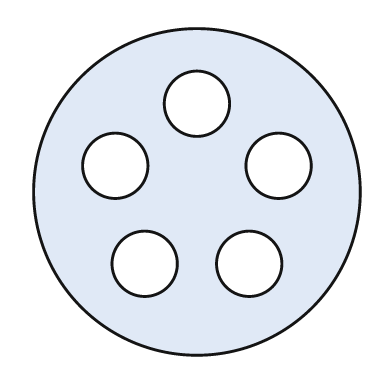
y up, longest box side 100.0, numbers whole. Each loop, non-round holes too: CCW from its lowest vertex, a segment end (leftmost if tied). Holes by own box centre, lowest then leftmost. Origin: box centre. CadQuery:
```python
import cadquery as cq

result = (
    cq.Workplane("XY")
    .moveTo(0.0, 0.0)
    .circle(50.0)
    .moveTo(-16.0, -22.0)
    .circle(10.0)
    .moveTo(16.0, -22.0)
    .circle(10.0)
    .moveTo(-25.0, 8.0)
    .circle(10.0)
    .moveTo(25.0, 8.0)
    .circle(10.0)
    .moveTo(0.0, 27.0)
    .circle(10.0)
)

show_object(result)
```